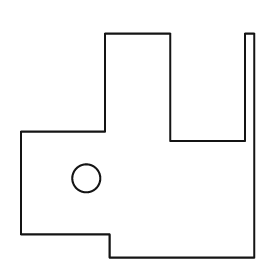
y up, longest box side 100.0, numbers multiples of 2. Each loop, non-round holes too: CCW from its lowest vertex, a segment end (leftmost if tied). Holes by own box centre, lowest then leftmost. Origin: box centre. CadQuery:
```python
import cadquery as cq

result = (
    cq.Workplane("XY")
    .moveTo(-12.0, -48.0)
    .lineTo(50.0, -48.0)
    .lineTo(50.0, 48.0)
    .lineTo(46.0, 48.0)
    .lineTo(46.0, 2.0)
    .lineTo(14.0, 2.0)
    .lineTo(14.0, 48.0)
    .lineTo(-14.0, 48.0)
    .lineTo(-14.0, 6.0)
    .lineTo(-50.0, 6.0)
    .lineTo(-50.0, -38.0)
    .lineTo(-12.0, -38.0)
    .close()
    .moveTo(-22.0, -14.0)
    .circle(6.0)
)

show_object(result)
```